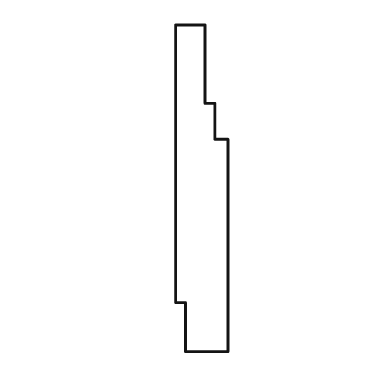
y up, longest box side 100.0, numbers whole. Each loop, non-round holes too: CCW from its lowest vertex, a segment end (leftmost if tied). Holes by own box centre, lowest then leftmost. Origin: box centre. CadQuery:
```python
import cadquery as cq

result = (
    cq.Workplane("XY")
    .moveTo(-5.0, -50.0)
    .lineTo(8.0, -50.0)
    .lineTo(8.0, 15.0)
    .lineTo(4.0, 15.0)
    .lineTo(4.0, 26.0)
    .lineTo(1.0, 26.0)
    .lineTo(1.0, 50.0)
    .lineTo(-8.0, 50.0)
    .lineTo(-8.0, -35.0)
    .lineTo(-5.0, -35.0)
    .close()
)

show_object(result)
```